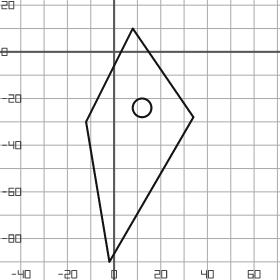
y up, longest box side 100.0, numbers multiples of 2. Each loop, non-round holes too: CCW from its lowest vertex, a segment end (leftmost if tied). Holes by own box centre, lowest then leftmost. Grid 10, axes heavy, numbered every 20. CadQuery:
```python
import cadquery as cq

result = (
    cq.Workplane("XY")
    .moveTo(-2.0, -90.0)
    .lineTo(34.0, -28.0)
    .lineTo(8.0, 10.0)
    .lineTo(-12.0, -30.0)
    .close()
    .moveTo(12.0, -24.0)
    .circle(4.0)
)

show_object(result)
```